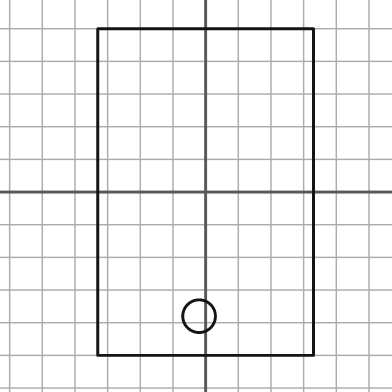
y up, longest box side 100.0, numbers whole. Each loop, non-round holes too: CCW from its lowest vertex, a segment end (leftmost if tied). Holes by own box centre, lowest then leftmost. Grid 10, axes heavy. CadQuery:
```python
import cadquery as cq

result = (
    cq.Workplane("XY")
    .moveTo(-33.0, -50.0)
    .lineTo(33.0, -50.0)
    .lineTo(33.0, 50.0)
    .lineTo(-33.0, 50.0)
    .close()
    .moveTo(-2.0, -38.0)
    .circle(5.0)
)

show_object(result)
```